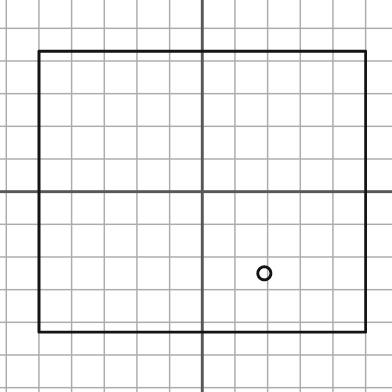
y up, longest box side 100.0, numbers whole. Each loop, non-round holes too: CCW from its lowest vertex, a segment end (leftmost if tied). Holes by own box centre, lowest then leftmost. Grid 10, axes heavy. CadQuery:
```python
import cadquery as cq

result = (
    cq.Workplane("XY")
    .moveTo(-50.0, -43.0)
    .lineTo(50.0, -43.0)
    .lineTo(50.0, 43.0)
    .lineTo(-50.0, 43.0)
    .close()
    .moveTo(19.0, -25.0)
    .circle(2.0)
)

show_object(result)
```